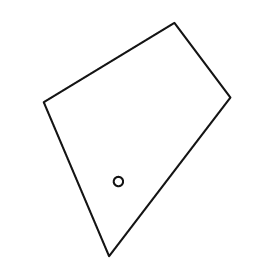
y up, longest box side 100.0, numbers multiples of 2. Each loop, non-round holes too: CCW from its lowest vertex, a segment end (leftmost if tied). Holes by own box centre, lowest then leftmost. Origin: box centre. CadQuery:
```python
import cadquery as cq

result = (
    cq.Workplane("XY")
    .moveTo(-12.0, -50.0)
    .lineTo(40.0, 18.0)
    .lineTo(16.0, 50.0)
    .lineTo(-40.0, 16.0)
    .close()
    .moveTo(-8.0, -18.0)
    .circle(2.0)
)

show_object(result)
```